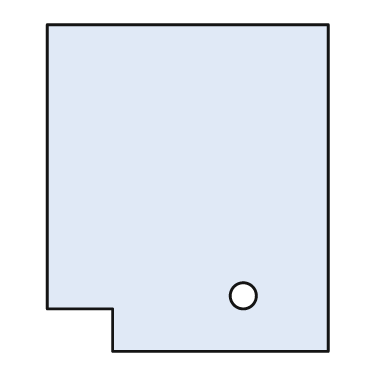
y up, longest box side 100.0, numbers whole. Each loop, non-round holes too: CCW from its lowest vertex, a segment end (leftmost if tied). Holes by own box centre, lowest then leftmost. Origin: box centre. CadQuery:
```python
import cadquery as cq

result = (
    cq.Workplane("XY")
    .moveTo(-23.0, -50.0)
    .lineTo(43.0, -50.0)
    .lineTo(43.0, 50.0)
    .lineTo(-43.0, 50.0)
    .lineTo(-43.0, -37.0)
    .lineTo(-23.0, -37.0)
    .close()
    .moveTo(17.0, -33.0)
    .circle(4.0)
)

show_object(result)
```